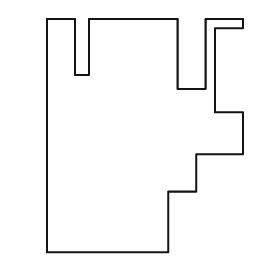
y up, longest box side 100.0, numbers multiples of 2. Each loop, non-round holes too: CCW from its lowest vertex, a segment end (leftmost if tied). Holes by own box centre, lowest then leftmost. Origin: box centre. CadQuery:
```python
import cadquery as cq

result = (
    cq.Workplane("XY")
    .moveTo(-42.0, -50.0)
    .lineTo(10.0, -50.0)
    .lineTo(10.0, -24.0)
    .lineTo(22.0, -24.0)
    .lineTo(22.0, -8.0)
    .lineTo(42.0, -8.0)
    .lineTo(42.0, 10.0)
    .lineTo(30.0, 10.0)
    .lineTo(30.0, 46.0)
    .lineTo(42.0, 46.0)
    .lineTo(42.0, 50.0)
    .lineTo(26.0, 50.0)
    .lineTo(26.0, 20.0)
    .lineTo(14.0, 20.0)
    .lineTo(14.0, 50.0)
    .lineTo(-24.0, 50.0)
    .lineTo(-24.0, 26.0)
    .lineTo(-30.0, 26.0)
    .lineTo(-30.0, 50.0)
    .lineTo(-42.0, 50.0)
    .close()
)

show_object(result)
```